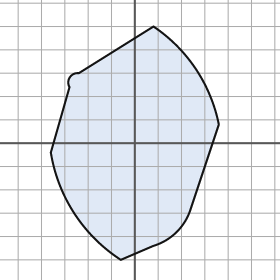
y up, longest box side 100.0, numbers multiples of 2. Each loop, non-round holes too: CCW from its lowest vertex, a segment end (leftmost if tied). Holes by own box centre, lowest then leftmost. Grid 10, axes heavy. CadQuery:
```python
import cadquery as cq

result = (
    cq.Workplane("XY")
    .moveTo(-6.0, -50.0)
    .lineTo(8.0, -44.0)
    .threePointArc((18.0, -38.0), (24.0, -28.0))
    .lineTo(36.0, 8.0)
    .threePointArc((26.0, 32.0), (8.0, 50.0))
    .lineTo(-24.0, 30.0)
    .threePointArc((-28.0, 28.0), (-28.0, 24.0))
    .lineTo(-36.0, -4.0)
    .threePointArc((-26.0, -30.0), (-6.0, -50.0))
    .close()
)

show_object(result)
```